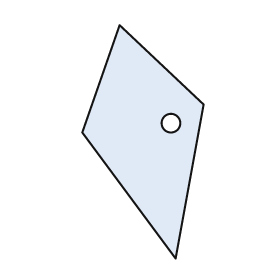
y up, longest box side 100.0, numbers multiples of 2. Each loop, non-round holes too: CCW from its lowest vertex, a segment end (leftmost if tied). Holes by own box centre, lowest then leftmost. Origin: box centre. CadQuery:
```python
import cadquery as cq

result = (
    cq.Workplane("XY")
    .moveTo(14.0, -50.0)
    .lineTo(26.0, 16.0)
    .lineTo(-10.0, 50.0)
    .lineTo(-26.0, 4.0)
    .close()
    .moveTo(12.0, 8.0)
    .circle(4.0)
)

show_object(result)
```